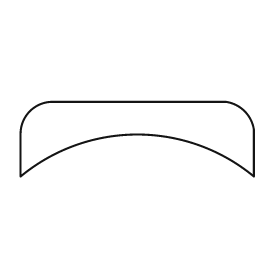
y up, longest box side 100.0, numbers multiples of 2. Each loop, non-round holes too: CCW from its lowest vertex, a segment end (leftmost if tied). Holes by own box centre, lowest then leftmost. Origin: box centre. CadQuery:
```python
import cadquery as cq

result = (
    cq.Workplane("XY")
    .moveTo(-50.0, -16.0)
    .threePointArc((0.0, 2.0), (50.0, -16.0))
    .lineTo(50.0, 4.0)
    .threePointArc((46.0, 12.0), (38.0, 16.0))
    .lineTo(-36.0, 16.0)
    .threePointArc((-46.0, 12.0), (-50.0, 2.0))
    .close()
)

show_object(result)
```